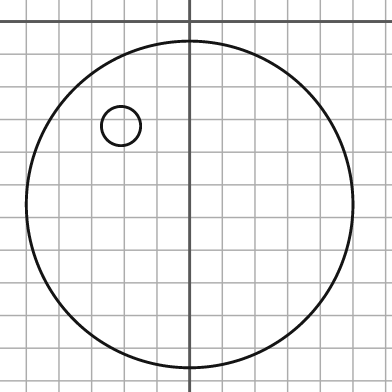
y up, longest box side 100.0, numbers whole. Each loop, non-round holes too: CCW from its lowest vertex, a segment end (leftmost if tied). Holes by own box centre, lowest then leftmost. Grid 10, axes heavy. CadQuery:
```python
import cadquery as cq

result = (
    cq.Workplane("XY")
    .moveTo(0.0, -56.0)
    .circle(50.0)
    .moveTo(-21.0, -32.0)
    .circle(6.0)
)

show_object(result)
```